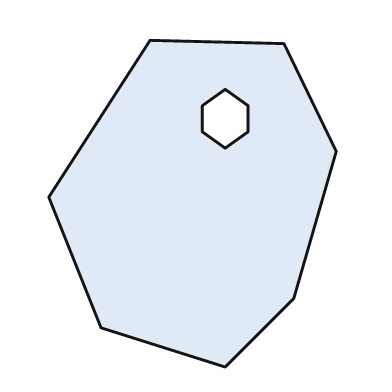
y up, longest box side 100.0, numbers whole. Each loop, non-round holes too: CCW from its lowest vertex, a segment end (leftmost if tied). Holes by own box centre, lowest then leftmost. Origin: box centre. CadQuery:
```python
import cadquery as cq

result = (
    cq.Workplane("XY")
    .moveTo(10.0, -50.0)
    .lineTo(31.0, -29.0)
    .lineTo(44.0, 16.0)
    .lineTo(28.0, 49.0)
    .lineTo(-13.0, 50.0)
    .lineTo(-44.0, 2.0)
    .lineTo(-28.0, -38.0)
    .close()
    .moveTo(10.0, 17.0)
    .lineTo(17.0, 22.0)
    .lineTo(17.0, 30.0)
    .lineTo(10.0, 35.0)
    .lineTo(3.0, 30.0)
    .lineTo(3.0, 22.0)
    .close()
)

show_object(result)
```